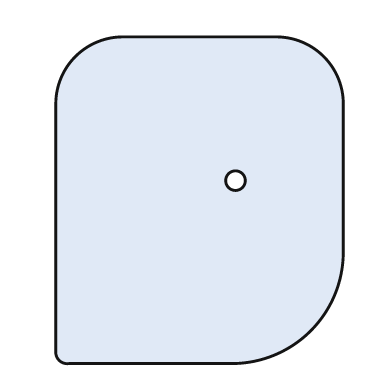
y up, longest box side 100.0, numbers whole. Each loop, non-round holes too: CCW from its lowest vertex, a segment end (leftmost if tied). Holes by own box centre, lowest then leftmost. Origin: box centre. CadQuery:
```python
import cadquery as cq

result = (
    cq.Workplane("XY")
    .moveTo(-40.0, -50.0)
    .lineTo(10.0, -50.0)
    .threePointArc((34.0, -40.0), (44.0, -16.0))
    .lineTo(44.0, 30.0)
    .threePointArc((38.0, 44.0), (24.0, 50.0))
    .lineTo(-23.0, 50.0)
    .threePointArc((-38.0, 44.0), (-44.0, 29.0))
    .lineTo(-44.0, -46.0)
    .threePointArc((-43.0, -49.0), (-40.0, -50.0))
    .close()
    .moveTo(11.0, 6.0)
    .circle(3.0)
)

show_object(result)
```